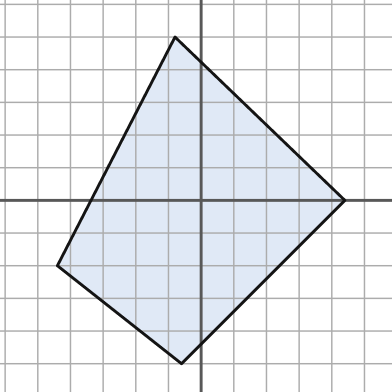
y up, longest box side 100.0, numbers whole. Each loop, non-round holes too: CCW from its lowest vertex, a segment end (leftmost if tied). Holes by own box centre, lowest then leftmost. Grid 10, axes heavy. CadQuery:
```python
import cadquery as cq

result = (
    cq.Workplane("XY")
    .moveTo(-6.0, -50.0)
    .lineTo(44.0, 0.0)
    .lineTo(-8.0, 50.0)
    .lineTo(-44.0, -20.0)
    .close()
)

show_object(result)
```